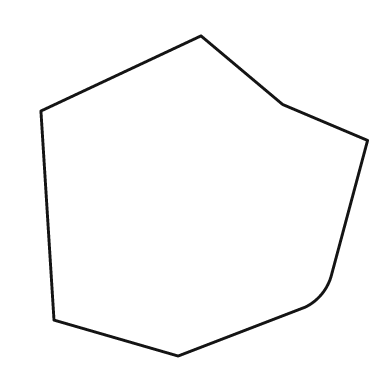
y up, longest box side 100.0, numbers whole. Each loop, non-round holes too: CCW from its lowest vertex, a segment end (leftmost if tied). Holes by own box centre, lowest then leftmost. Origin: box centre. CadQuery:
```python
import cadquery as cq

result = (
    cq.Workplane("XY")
    .moveTo(-8.0, -49.0)
    .lineTo(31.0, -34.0)
    .threePointArc((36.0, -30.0), (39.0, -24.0))
    .lineTo(50.0, 17.0)
    .lineTo(24.0, 28.0)
    .lineTo(-1.0, 49.0)
    .lineTo(-50.0, 26.0)
    .lineTo(-46.0, -38.0)
    .close()
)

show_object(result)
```